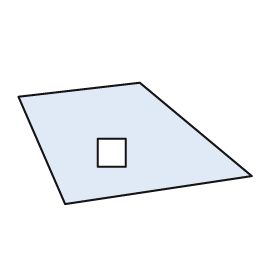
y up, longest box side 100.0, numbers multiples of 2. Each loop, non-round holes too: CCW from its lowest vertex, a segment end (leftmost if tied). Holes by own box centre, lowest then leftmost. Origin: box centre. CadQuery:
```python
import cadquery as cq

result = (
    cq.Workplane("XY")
    .moveTo(-30.0, -26.0)
    .lineTo(50.0, -14.0)
    .lineTo(2.0, 26.0)
    .lineTo(-50.0, 20.0)
    .close()
    .moveTo(-16.0, -10.0)
    .lineTo(-4.0, -10.0)
    .lineTo(-4.0, 2.0)
    .lineTo(-16.0, 2.0)
    .close()
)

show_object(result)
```